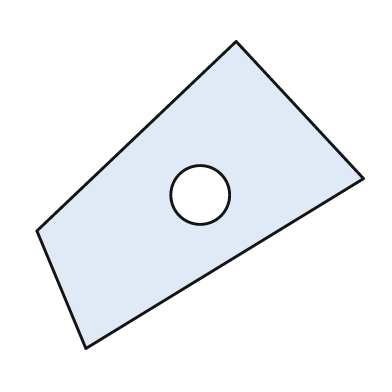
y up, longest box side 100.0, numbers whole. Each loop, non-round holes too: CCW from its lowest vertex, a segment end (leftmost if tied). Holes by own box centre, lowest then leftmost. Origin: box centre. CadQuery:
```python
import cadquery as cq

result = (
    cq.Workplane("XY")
    .moveTo(-35.0, -47.0)
    .lineTo(50.0, 5.0)
    .lineTo(11.0, 47.0)
    .lineTo(-50.0, -11.0)
    .close()
    .moveTo(0.0, 0.0)
    .circle(9.0)
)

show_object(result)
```